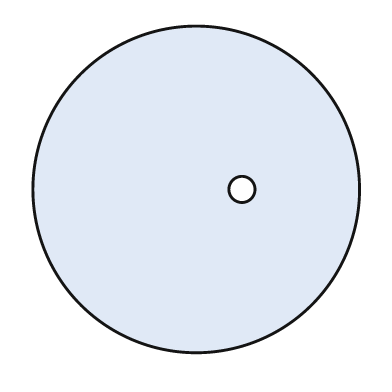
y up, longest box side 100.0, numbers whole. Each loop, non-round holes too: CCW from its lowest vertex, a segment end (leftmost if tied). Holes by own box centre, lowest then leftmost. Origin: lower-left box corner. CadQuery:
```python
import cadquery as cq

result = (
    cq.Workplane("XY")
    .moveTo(50.0, 50.0)
    .circle(50.0)
    .moveTo(64.0, 50.0)
    .circle(4.0)
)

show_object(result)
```